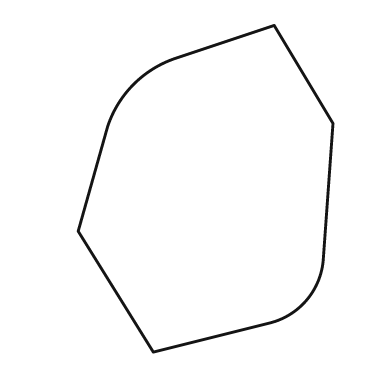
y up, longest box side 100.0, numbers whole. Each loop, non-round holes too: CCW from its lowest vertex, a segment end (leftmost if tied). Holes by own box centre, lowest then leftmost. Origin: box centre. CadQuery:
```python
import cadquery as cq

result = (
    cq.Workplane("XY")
    .moveTo(-16.0, -50.0)
    .lineTo(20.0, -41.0)
    .threePointArc((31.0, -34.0), (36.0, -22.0))
    .lineTo(39.0, 20.0)
    .lineTo(21.0, 50.0)
    .lineTo(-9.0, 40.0)
    .threePointArc((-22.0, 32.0), (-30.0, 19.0))
    .lineTo(-39.0, -13.0)
    .close()
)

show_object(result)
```